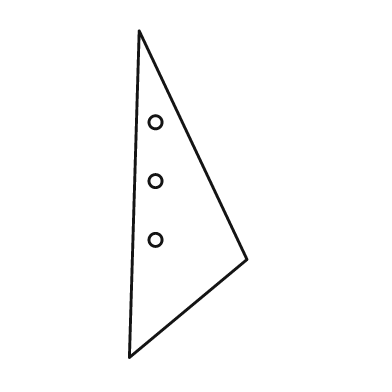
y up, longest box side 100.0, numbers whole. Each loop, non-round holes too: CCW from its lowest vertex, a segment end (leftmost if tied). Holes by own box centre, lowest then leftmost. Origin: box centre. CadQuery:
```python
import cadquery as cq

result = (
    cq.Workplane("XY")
    .moveTo(-18.0, -50.0)
    .lineTo(18.0, -20.0)
    .lineTo(-15.0, 50.0)
    .close()
    .moveTo(-10.0, -14.0)
    .circle(2.0)
    .moveTo(-10.0, 4.0)
    .circle(2.0)
    .moveTo(-10.0, 22.0)
    .circle(2.0)
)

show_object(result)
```